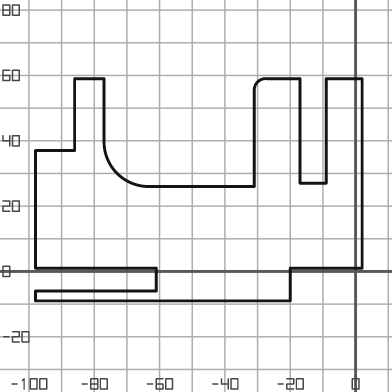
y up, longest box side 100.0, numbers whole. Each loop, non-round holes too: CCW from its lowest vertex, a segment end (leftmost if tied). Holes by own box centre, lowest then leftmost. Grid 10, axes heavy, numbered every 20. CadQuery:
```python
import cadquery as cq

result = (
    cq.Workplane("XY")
    .moveTo(-98.0, -9.0)
    .lineTo(-20.0, -9.0)
    .lineTo(-20.0, 1.0)
    .lineTo(2.0, 1.0)
    .lineTo(2.0, 59.0)
    .lineTo(-9.0, 59.0)
    .lineTo(-9.0, 27.0)
    .lineTo(-17.0, 27.0)
    .lineTo(-17.0, 59.0)
    .lineTo(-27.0, 59.0)
    .threePointArc((-30.0, 58.0), (-31.0, 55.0))
    .lineTo(-31.0, 26.0)
    .lineTo(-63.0, 26.0)
    .threePointArc((-73.0, 30.0), (-77.0, 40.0))
    .lineTo(-77.0, 59.0)
    .lineTo(-86.0, 59.0)
    .lineTo(-86.0, 37.0)
    .lineTo(-98.0, 37.0)
    .lineTo(-98.0, 1.0)
    .lineTo(-61.0, 1.0)
    .lineTo(-61.0, -6.0)
    .lineTo(-98.0, -6.0)
    .close()
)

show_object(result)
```